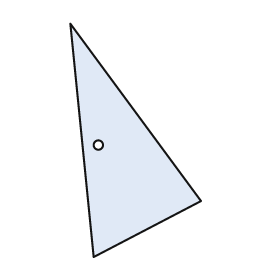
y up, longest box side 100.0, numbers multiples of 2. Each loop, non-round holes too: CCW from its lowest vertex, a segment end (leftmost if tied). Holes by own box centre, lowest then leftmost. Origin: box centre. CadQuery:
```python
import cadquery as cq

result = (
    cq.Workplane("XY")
    .moveTo(-18.0, -50.0)
    .lineTo(28.0, -26.0)
    .lineTo(-28.0, 50.0)
    .close()
    .moveTo(-16.0, -2.0)
    .circle(2.0)
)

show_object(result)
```